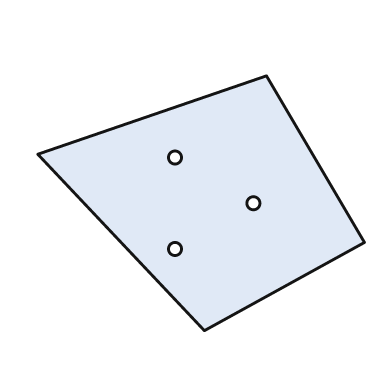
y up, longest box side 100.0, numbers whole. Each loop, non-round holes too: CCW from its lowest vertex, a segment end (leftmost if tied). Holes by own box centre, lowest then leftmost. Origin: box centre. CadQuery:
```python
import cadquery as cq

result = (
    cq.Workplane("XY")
    .moveTo(1.0, -39.0)
    .lineTo(50.0, -12.0)
    .lineTo(20.0, 39.0)
    .lineTo(-50.0, 15.0)
    .close()
    .moveTo(-8.0, -14.0)
    .circle(2.0)
    .moveTo(16.0, 0.0)
    .circle(2.0)
    .moveTo(-8.0, 14.0)
    .circle(2.0)
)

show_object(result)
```